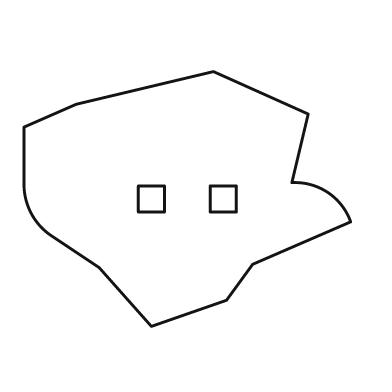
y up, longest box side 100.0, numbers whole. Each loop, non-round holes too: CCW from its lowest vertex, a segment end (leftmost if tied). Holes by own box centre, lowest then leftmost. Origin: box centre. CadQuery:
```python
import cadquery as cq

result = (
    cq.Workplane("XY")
    .moveTo(-11.0, -39.0)
    .lineTo(12.0, -31.0)
    .lineTo(20.0, -20.0)
    .lineTo(50.0, -7.0)
    .threePointArc((43.0, 2.0), (32.0, 5.0))
    .lineTo(37.0, 26.0)
    .lineTo(8.0, 39.0)
    .lineTo(-34.0, 29.0)
    .lineTo(-50.0, 22.0)
    .lineTo(-50.0, 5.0)
    .threePointArc((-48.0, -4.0), (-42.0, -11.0))
    .lineTo(-27.0, -21.0)
    .close()
    .moveTo(-15.0, -4.0)
    .lineTo(-7.0, -4.0)
    .lineTo(-7.0, 4.0)
    .lineTo(-15.0, 4.0)
    .close()
    .moveTo(7.0, -4.0)
    .lineTo(15.0, -4.0)
    .lineTo(15.0, 4.0)
    .lineTo(7.0, 4.0)
    .close()
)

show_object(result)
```